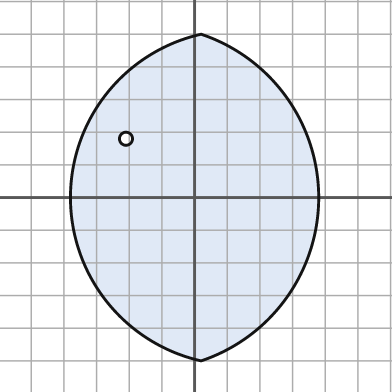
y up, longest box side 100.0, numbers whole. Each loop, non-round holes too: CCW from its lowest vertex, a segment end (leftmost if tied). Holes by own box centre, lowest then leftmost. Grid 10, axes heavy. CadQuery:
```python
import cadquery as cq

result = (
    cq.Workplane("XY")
    .moveTo(2.0, -50.0)
    .threePointArc((38.0, 0.0), (2.0, 50.0))
    .threePointArc((-38.0, 0.0), (2.0, -50.0))
    .close()
    .moveTo(-21.0, 18.0)
    .circle(2.0)
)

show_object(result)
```